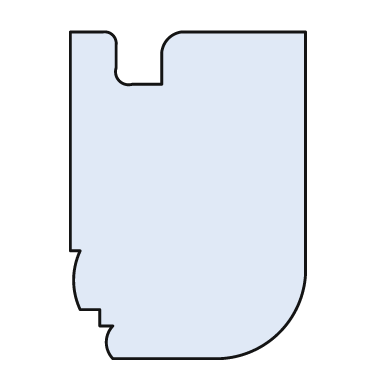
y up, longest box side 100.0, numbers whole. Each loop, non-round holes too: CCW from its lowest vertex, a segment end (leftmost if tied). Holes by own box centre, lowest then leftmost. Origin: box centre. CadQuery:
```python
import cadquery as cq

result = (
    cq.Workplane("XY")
    .moveTo(-23.0, -50.0)
    .lineTo(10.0, -50.0)
    .threePointArc((28.0, -42.0), (36.0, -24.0))
    .lineTo(36.0, 50.0)
    .lineTo(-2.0, 50.0)
    .threePointArc((-6.0, 48.0), (-8.0, 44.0))
    .lineTo(-8.0, 34.0)
    .lineTo(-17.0, 34.0)
    .threePointArc((-21.0, 35.0), (-22.0, 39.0))
    .lineTo(-22.0, 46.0)
    .threePointArc((-23.0, 49.0), (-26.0, 50.0))
    .lineTo(-36.0, 50.0)
    .lineTo(-36.0, -17.0)
    .lineTo(-33.0, -17.0)
    .threePointArc((-35.0, -26.0), (-33.0, -35.0))
    .lineTo(-27.0, -35.0)
    .lineTo(-27.0, -40.0)
    .lineTo(-23.0, -40.0)
    .threePointArc((-25.0, -45.0), (-23.0, -50.0))
    .close()
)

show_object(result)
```